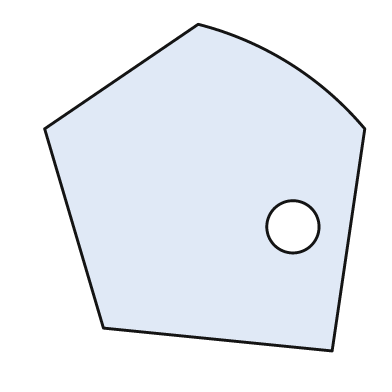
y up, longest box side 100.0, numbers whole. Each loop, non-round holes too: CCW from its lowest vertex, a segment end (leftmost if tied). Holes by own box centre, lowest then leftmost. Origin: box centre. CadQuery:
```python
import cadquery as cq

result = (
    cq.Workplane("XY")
    .moveTo(39.0, -50.0)
    .lineTo(49.0, 18.0)
    .threePointArc((26.0, 38.0), (-2.0, 50.0))
    .lineTo(-49.0, 18.0)
    .lineTo(-31.0, -43.0)
    .close()
    .moveTo(27.0, -12.0)
    .circle(8.0)
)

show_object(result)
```